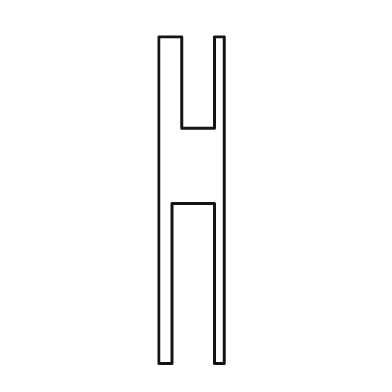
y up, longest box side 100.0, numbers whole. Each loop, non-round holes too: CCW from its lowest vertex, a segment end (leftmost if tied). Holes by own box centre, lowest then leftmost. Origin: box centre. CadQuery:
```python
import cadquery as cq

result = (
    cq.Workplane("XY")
    .moveTo(-10.0, -50.0)
    .lineTo(-6.0, -50.0)
    .lineTo(-6.0, -1.0)
    .lineTo(7.0, -1.0)
    .lineTo(7.0, -50.0)
    .lineTo(10.0, -50.0)
    .lineTo(10.0, 50.0)
    .lineTo(7.0, 50.0)
    .lineTo(7.0, 22.0)
    .lineTo(-3.0, 22.0)
    .lineTo(-3.0, 50.0)
    .lineTo(-10.0, 50.0)
    .close()
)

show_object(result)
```